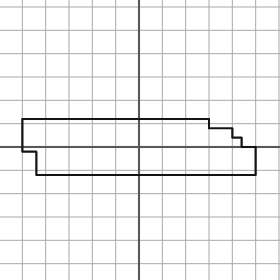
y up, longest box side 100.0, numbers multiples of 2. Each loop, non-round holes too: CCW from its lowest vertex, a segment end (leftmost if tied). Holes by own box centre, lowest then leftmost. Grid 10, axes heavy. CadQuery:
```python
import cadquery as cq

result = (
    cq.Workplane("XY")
    .moveTo(-44.0, -12.0)
    .lineTo(50.0, -12.0)
    .lineTo(50.0, 0.0)
    .lineTo(44.0, 0.0)
    .lineTo(44.0, 4.0)
    .lineTo(40.0, 4.0)
    .lineTo(40.0, 8.0)
    .lineTo(30.0, 8.0)
    .lineTo(30.0, 12.0)
    .lineTo(-50.0, 12.0)
    .lineTo(-50.0, -2.0)
    .lineTo(-44.0, -2.0)
    .close()
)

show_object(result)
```